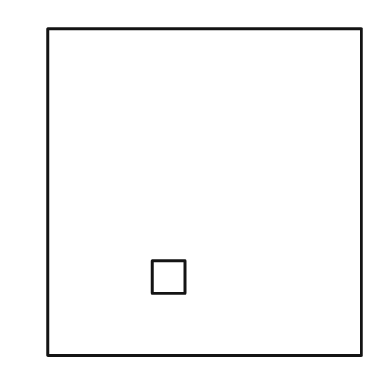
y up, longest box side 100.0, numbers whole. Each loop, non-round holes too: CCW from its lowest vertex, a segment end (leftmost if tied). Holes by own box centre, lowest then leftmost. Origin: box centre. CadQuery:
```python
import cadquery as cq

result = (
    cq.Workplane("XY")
    .moveTo(-48.0, -50.0)
    .lineTo(48.0, -50.0)
    .lineTo(48.0, 50.0)
    .lineTo(-48.0, 50.0)
    .close()
    .moveTo(-16.0, -31.0)
    .lineTo(-6.0, -31.0)
    .lineTo(-6.0, -21.0)
    .lineTo(-16.0, -21.0)
    .close()
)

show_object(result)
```